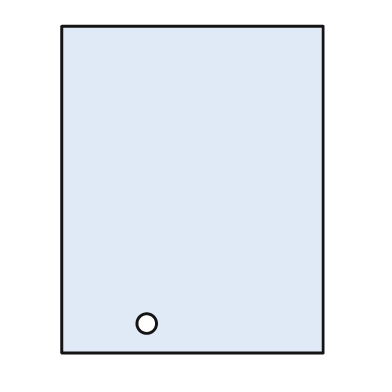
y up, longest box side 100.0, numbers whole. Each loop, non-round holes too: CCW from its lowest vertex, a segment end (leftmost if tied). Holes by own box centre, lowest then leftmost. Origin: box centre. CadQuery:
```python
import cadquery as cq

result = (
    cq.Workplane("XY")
    .moveTo(-40.0, -50.0)
    .lineTo(40.0, -50.0)
    .lineTo(40.0, 50.0)
    .lineTo(-40.0, 50.0)
    .close()
    .moveTo(-14.0, -41.0)
    .circle(3.0)
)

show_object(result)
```